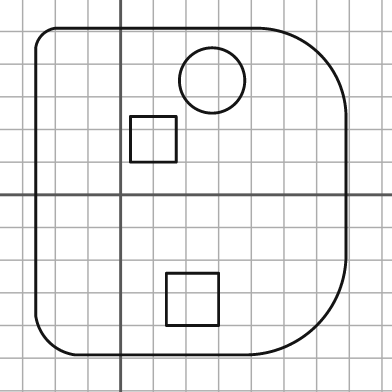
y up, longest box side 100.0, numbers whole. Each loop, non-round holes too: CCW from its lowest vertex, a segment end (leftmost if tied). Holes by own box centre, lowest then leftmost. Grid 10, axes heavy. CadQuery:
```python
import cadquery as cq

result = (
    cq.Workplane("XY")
    .moveTo(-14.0, -49.0)
    .lineTo(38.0, -49.0)
    .threePointArc((60.0, -40.0), (69.0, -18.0))
    .lineTo(69.0, 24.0)
    .threePointArc((61.0, 43.0), (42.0, 51.0))
    .lineTo(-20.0, 51.0)
    .threePointArc((-24.0, 49.0), (-26.0, 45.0))
    .lineTo(-26.0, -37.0)
    .threePointArc((-22.0, -45.0), (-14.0, -49.0))
    .close()
    .moveTo(14.0, -40.0)
    .lineTo(30.0, -40.0)
    .lineTo(30.0, -24.0)
    .lineTo(14.0, -24.0)
    .close()
    .moveTo(3.0, 10.0)
    .lineTo(17.0, 10.0)
    .lineTo(17.0, 24.0)
    .lineTo(3.0, 24.0)
    .close()
    .moveTo(28.0, 35.0)
    .circle(10.0)
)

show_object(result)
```